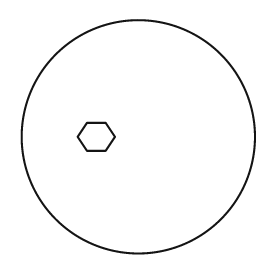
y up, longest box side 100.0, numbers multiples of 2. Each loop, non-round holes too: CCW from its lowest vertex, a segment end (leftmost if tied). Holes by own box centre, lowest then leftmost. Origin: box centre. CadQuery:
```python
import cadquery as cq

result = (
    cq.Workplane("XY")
    .moveTo(0.0, 0.0)
    .circle(50.0)
    .moveTo(-22.0, -6.0)
    .lineTo(-14.0, -6.0)
    .lineTo(-10.0, 0.0)
    .lineTo(-14.0, 6.0)
    .lineTo(-22.0, 6.0)
    .lineTo(-26.0, 0.0)
    .close()
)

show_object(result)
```